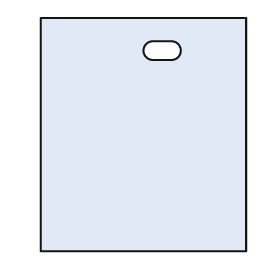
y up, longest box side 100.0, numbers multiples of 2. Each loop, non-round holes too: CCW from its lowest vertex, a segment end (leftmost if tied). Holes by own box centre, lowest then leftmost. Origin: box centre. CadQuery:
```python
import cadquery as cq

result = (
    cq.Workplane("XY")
    .moveTo(-44.0, -50.0)
    .lineTo(44.0, -50.0)
    .lineTo(44.0, 50.0)
    .lineTo(-44.0, 50.0)
    .close()
    .moveTo(4.0, 32.0)
    .lineTo(12.0, 32.0)
    .threePointArc((16.0, 36.0), (12.0, 40.0))
    .lineTo(4.0, 40.0)
    .threePointArc((0.0, 36.0), (4.0, 32.0))
    .close()
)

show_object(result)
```